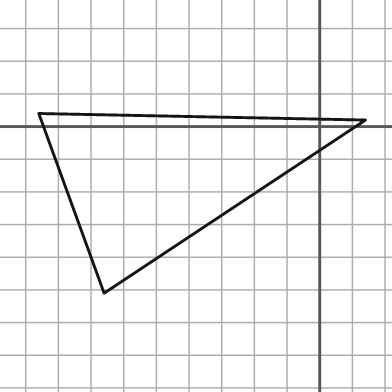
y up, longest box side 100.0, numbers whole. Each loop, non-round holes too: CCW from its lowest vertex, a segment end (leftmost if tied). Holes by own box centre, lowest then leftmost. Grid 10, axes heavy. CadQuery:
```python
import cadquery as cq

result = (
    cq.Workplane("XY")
    .moveTo(-66.0, -51.0)
    .lineTo(14.0, 2.0)
    .lineTo(-86.0, 4.0)
    .close()
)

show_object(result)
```